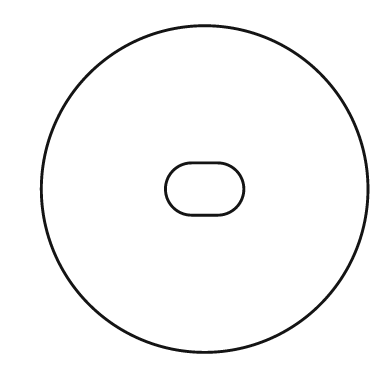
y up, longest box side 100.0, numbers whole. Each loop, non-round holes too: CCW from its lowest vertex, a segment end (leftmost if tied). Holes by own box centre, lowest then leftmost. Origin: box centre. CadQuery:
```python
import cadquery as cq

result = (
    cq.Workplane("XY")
    .moveTo(0.0, 0.0)
    .circle(50.0)
    .moveTo(-4.0, -8.0)
    .lineTo(4.0, -8.0)
    .threePointArc((12.0, 0.0), (4.0, 8.0))
    .lineTo(-4.0, 8.0)
    .threePointArc((-12.0, 0.0), (-4.0, -8.0))
    .close()
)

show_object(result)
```